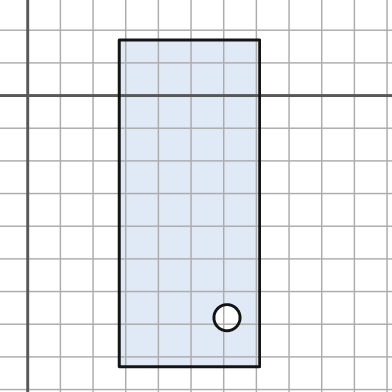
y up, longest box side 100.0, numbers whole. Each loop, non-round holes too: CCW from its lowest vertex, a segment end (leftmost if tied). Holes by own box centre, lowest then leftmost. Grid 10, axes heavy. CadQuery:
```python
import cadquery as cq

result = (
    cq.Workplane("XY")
    .moveTo(28.0, -83.0)
    .lineTo(71.0, -83.0)
    .lineTo(71.0, 17.0)
    .lineTo(28.0, 17.0)
    .close()
    .moveTo(61.0, -68.0)
    .circle(4.0)
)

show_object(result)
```